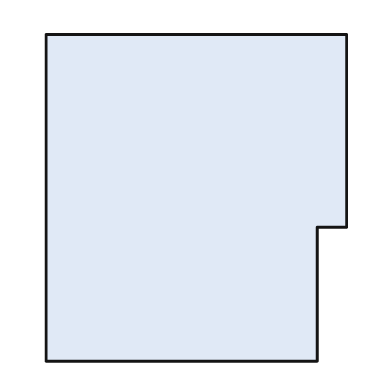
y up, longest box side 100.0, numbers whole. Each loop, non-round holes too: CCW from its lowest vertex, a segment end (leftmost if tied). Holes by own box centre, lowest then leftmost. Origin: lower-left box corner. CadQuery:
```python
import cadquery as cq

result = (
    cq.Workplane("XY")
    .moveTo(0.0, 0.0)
    .lineTo(83.0, 0.0)
    .lineTo(83.0, 41.0)
    .lineTo(92.0, 41.0)
    .lineTo(92.0, 100.0)
    .lineTo(0.0, 100.0)
    .close()
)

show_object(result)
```